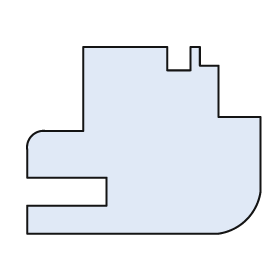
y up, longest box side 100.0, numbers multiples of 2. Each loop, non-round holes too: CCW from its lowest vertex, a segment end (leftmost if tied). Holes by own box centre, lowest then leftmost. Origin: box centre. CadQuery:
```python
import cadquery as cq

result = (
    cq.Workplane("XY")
    .moveTo(-50.0, -40.0)
    .lineTo(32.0, -40.0)
    .threePointArc((44.0, -34.0), (50.0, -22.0))
    .lineTo(50.0, 10.0)
    .lineTo(32.0, 10.0)
    .lineTo(32.0, 32.0)
    .lineTo(24.0, 32.0)
    .lineTo(24.0, 40.0)
    .lineTo(20.0, 40.0)
    .lineTo(20.0, 30.0)
    .lineTo(10.0, 30.0)
    .lineTo(10.0, 40.0)
    .lineTo(-26.0, 40.0)
    .lineTo(-26.0, 4.0)
    .lineTo(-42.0, 4.0)
    .threePointArc((-48.0, 2.0), (-50.0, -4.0))
    .lineTo(-50.0, -16.0)
    .lineTo(-16.0, -16.0)
    .lineTo(-16.0, -28.0)
    .lineTo(-50.0, -28.0)
    .close()
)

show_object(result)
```